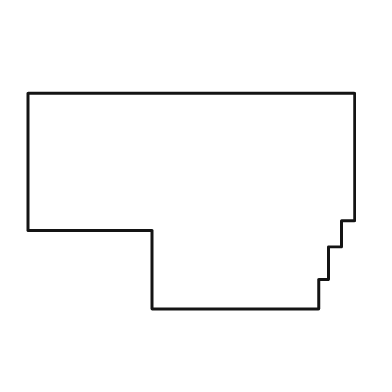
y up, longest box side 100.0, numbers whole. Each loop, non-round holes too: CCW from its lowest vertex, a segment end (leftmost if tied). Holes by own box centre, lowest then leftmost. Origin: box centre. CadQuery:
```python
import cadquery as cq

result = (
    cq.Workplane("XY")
    .moveTo(-12.0, -33.0)
    .lineTo(39.0, -33.0)
    .lineTo(39.0, -24.0)
    .lineTo(42.0, -24.0)
    .lineTo(42.0, -14.0)
    .lineTo(46.0, -14.0)
    .lineTo(46.0, -6.0)
    .lineTo(50.0, -6.0)
    .lineTo(50.0, 33.0)
    .lineTo(-50.0, 33.0)
    .lineTo(-50.0, -9.0)
    .lineTo(-12.0, -9.0)
    .close()
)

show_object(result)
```